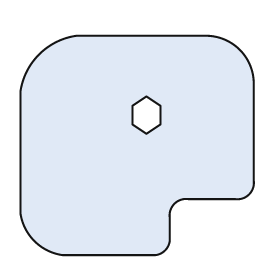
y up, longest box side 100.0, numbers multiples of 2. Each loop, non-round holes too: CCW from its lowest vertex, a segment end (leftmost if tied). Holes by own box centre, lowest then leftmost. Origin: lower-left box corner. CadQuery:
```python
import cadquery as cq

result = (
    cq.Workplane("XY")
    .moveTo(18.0, 0.0)
    .lineTo(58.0, 0.0)
    .threePointArc((62.0, 2.0), (64.0, 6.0))
    .lineTo(64.0, 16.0)
    .threePointArc((66.0, 22.0), (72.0, 24.0))
    .lineTo(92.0, 24.0)
    .threePointArc((98.0, 26.0), (100.0, 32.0))
    .lineTo(100.0, 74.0)
    .threePointArc((94.0, 88.0), (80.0, 94.0))
    .lineTo(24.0, 94.0)
    .threePointArc((8.0, 86.0), (0.0, 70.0))
    .lineTo(0.0, 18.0)
    .threePointArc((6.0, 6.0), (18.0, 0.0))
    .close()
    .moveTo(54.0, 52.0)
    .lineTo(60.0, 56.0)
    .lineTo(60.0, 64.0)
    .lineTo(54.0, 68.0)
    .lineTo(48.0, 64.0)
    .lineTo(48.0, 56.0)
    .close()
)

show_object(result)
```